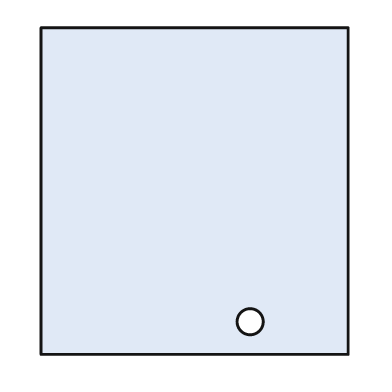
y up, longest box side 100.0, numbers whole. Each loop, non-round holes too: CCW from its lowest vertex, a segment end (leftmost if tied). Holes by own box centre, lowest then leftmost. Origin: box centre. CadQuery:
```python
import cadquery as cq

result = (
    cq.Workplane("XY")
    .moveTo(-47.0, -50.0)
    .lineTo(47.0, -50.0)
    .lineTo(47.0, 50.0)
    .lineTo(-47.0, 50.0)
    .close()
    .moveTo(17.0, -40.0)
    .circle(4.0)
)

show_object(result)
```